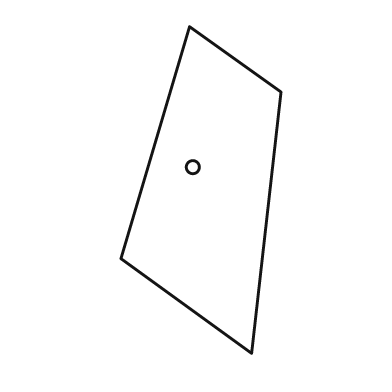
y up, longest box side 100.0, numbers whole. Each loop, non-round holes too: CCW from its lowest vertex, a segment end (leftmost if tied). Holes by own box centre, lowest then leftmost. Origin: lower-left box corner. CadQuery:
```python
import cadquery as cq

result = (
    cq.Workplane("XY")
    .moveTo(40.0, 0.0)
    .lineTo(49.0, 80.0)
    .lineTo(21.0, 100.0)
    .lineTo(0.0, 29.0)
    .close()
    .moveTo(22.0, 57.0)
    .circle(2.0)
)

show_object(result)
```